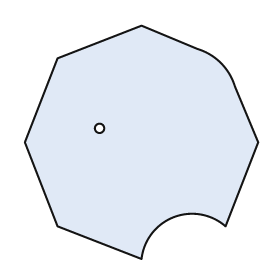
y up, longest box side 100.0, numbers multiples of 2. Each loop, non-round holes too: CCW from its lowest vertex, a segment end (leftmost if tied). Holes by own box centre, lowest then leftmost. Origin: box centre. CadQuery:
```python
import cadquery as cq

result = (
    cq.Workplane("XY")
    .moveTo(0.0, -50.0)
    .threePointArc((14.0, -32.0), (36.0, -36.0))
    .lineTo(50.0, 0.0)
    .lineTo(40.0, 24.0)
    .threePointArc((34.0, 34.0), (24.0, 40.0))
    .lineTo(0.0, 50.0)
    .lineTo(-36.0, 36.0)
    .lineTo(-50.0, 0.0)
    .lineTo(-36.0, -36.0)
    .close()
    .moveTo(-18.0, 6.0)
    .circle(2.0)
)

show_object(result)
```